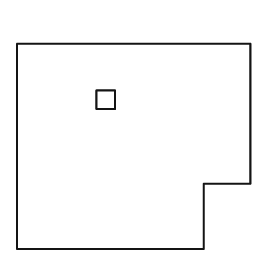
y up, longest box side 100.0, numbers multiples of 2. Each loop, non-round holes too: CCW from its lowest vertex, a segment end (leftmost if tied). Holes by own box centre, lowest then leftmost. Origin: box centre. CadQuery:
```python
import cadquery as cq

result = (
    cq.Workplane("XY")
    .moveTo(-50.0, -44.0)
    .lineTo(30.0, -44.0)
    .lineTo(30.0, -16.0)
    .lineTo(50.0, -16.0)
    .lineTo(50.0, 44.0)
    .lineTo(-50.0, 44.0)
    .close()
    .moveTo(-16.0, 16.0)
    .lineTo(-8.0, 16.0)
    .lineTo(-8.0, 24.0)
    .lineTo(-16.0, 24.0)
    .close()
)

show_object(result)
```